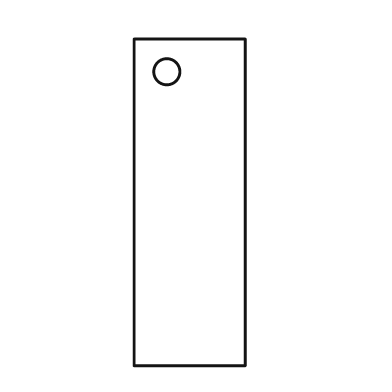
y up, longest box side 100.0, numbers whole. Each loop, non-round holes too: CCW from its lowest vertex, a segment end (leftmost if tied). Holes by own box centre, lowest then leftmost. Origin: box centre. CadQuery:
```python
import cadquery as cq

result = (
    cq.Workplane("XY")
    .moveTo(-17.0, -50.0)
    .lineTo(17.0, -50.0)
    .lineTo(17.0, 50.0)
    .lineTo(-17.0, 50.0)
    .close()
    .moveTo(-7.0, 40.0)
    .circle(4.0)
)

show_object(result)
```